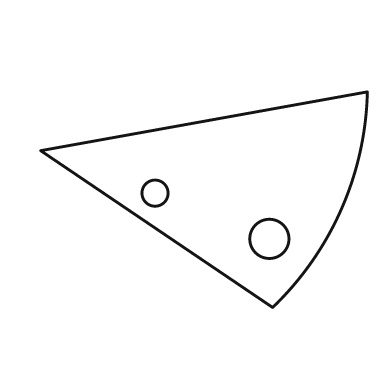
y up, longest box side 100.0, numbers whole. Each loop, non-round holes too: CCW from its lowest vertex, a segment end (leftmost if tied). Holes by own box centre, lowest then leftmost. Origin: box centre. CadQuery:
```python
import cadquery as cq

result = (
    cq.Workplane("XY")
    .moveTo(21.0, -33.0)
    .threePointArc((42.0, -3.0), (50.0, 33.0))
    .lineTo(-50.0, 15.0)
    .close()
    .moveTo(20.0, -12.0)
    .circle(6.0)
    .moveTo(-15.0, 2.0)
    .circle(4.0)
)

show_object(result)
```